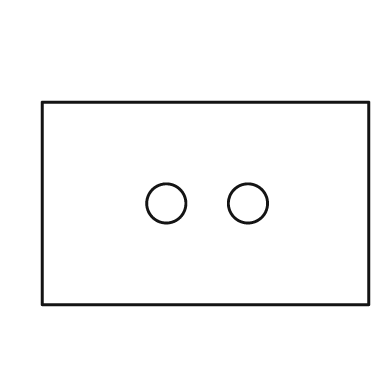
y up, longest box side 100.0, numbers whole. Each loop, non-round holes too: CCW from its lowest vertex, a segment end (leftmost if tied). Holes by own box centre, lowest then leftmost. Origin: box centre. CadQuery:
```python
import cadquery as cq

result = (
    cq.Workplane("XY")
    .moveTo(-50.0, -31.0)
    .lineTo(50.0, -31.0)
    .lineTo(50.0, 31.0)
    .lineTo(-50.0, 31.0)
    .close()
    .moveTo(-12.0, 0.0)
    .circle(6.0)
    .moveTo(13.0, 0.0)
    .circle(6.0)
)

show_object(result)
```